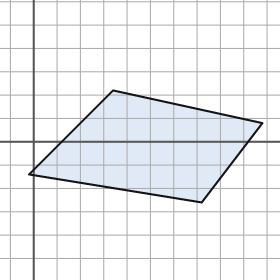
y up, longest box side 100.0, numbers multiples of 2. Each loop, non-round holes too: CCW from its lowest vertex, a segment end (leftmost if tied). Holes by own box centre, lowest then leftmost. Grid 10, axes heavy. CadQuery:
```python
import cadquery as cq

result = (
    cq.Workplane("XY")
    .moveTo(72.0, -26.0)
    .lineTo(98.0, 8.0)
    .lineTo(34.0, 22.0)
    .lineTo(-2.0, -14.0)
    .close()
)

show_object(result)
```